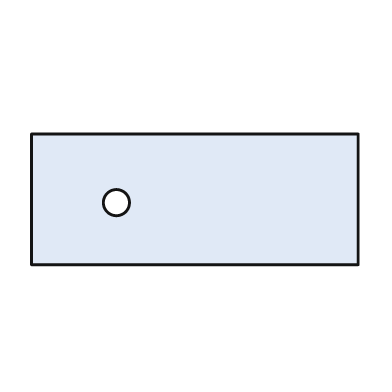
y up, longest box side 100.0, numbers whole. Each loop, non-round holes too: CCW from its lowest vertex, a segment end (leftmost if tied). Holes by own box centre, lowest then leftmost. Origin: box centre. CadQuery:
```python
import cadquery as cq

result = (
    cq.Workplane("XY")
    .moveTo(-50.0, -20.0)
    .lineTo(50.0, -20.0)
    .lineTo(50.0, 20.0)
    .lineTo(-50.0, 20.0)
    .close()
    .moveTo(-24.0, -1.0)
    .circle(4.0)
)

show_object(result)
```